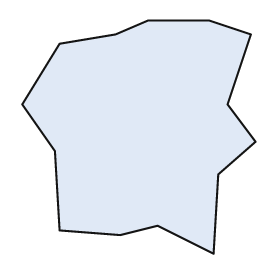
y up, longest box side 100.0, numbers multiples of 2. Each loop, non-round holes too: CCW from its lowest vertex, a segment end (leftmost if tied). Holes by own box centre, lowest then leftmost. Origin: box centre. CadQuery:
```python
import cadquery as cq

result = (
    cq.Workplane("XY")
    .moveTo(32.0, -50.0)
    .lineTo(34.0, -16.0)
    .lineTo(50.0, -2.0)
    .lineTo(38.0, 14.0)
    .lineTo(48.0, 44.0)
    .lineTo(30.0, 50.0)
    .lineTo(4.0, 50.0)
    .lineTo(-10.0, 44.0)
    .lineTo(-34.0, 40.0)
    .lineTo(-50.0, 14.0)
    .lineTo(-36.0, -6.0)
    .lineTo(-34.0, -40.0)
    .lineTo(-8.0, -42.0)
    .lineTo(8.0, -38.0)
    .close()
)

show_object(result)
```